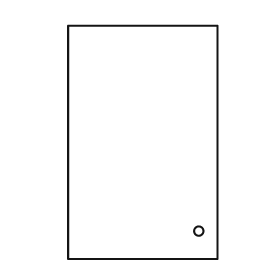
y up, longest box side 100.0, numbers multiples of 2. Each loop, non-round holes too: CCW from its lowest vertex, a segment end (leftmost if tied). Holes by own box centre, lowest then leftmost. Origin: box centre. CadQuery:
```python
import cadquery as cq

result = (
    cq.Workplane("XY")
    .moveTo(-32.0, -50.0)
    .lineTo(32.0, -50.0)
    .lineTo(32.0, 50.0)
    .lineTo(-32.0, 50.0)
    .close()
    .moveTo(24.0, -38.0)
    .circle(2.0)
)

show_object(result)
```